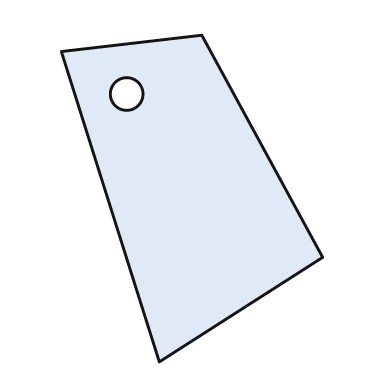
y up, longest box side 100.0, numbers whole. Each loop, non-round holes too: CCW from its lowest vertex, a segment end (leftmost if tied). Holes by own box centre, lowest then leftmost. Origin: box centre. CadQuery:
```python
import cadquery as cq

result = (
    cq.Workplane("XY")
    .moveTo(-10.0, -50.0)
    .lineTo(40.0, -18.0)
    .lineTo(3.0, 50.0)
    .lineTo(-40.0, 45.0)
    .close()
    .moveTo(-20.0, 32.0)
    .circle(5.0)
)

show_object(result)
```